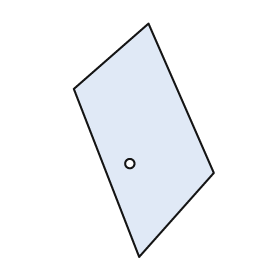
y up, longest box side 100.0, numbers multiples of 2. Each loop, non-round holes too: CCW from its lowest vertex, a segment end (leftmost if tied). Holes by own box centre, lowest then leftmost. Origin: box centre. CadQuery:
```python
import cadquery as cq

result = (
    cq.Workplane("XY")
    .moveTo(-2.0, -50.0)
    .lineTo(30.0, -14.0)
    .lineTo(2.0, 50.0)
    .lineTo(-30.0, 22.0)
    .close()
    .moveTo(-6.0, -10.0)
    .circle(2.0)
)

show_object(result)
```